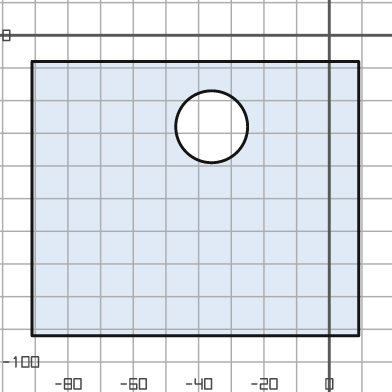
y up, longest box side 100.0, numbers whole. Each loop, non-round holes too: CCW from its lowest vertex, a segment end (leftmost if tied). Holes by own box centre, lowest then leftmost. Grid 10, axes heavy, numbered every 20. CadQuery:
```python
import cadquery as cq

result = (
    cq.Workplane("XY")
    .moveTo(-91.0, -92.0)
    .lineTo(9.0, -92.0)
    .lineTo(9.0, -8.0)
    .lineTo(-91.0, -8.0)
    .close()
    .moveTo(-36.0, -28.0)
    .circle(11.0)
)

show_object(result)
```